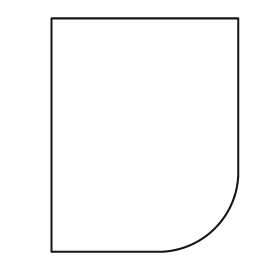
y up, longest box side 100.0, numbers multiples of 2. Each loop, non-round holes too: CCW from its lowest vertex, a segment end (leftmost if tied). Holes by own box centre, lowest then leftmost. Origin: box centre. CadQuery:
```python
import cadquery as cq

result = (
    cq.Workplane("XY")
    .moveTo(-40.0, -50.0)
    .lineTo(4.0, -50.0)
    .threePointArc((30.0, -40.0), (40.0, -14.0))
    .lineTo(40.0, 50.0)
    .lineTo(-40.0, 50.0)
    .close()
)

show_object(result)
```